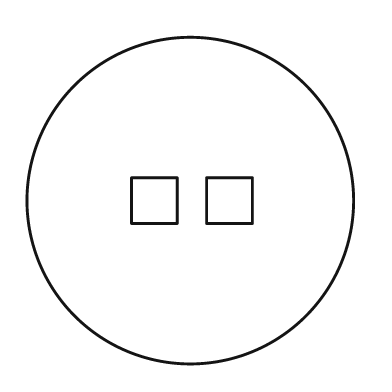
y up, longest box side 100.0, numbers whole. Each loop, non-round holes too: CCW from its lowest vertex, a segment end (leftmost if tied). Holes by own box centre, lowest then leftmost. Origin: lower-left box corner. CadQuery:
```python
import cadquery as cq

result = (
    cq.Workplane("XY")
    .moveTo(50.0, 50.0)
    .circle(50.0)
    .moveTo(32.0, 43.0)
    .lineTo(46.0, 43.0)
    .lineTo(46.0, 57.0)
    .lineTo(32.0, 57.0)
    .close()
    .moveTo(55.0, 43.0)
    .lineTo(69.0, 43.0)
    .lineTo(69.0, 57.0)
    .lineTo(55.0, 57.0)
    .close()
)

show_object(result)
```